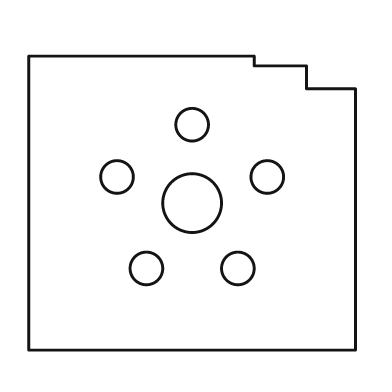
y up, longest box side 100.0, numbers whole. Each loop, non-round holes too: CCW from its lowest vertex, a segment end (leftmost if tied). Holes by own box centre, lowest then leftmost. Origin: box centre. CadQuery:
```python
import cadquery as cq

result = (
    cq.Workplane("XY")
    .moveTo(-50.0, -45.0)
    .lineTo(50.0, -45.0)
    .lineTo(50.0, 35.0)
    .lineTo(35.0, 35.0)
    .lineTo(35.0, 42.0)
    .lineTo(19.0, 42.0)
    .lineTo(19.0, 45.0)
    .lineTo(-50.0, 45.0)
    .close()
    .moveTo(-14.0, -20.0)
    .circle(5.0)
    .moveTo(14.0, -20.0)
    .circle(5.0)
    .moveTo(0.0, 0.0)
    .circle(9.0)
    .moveTo(-23.0, 8.0)
    .circle(5.0)
    .moveTo(23.0, 8.0)
    .circle(5.0)
    .moveTo(0.0, 24.0)
    .circle(5.0)
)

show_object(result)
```